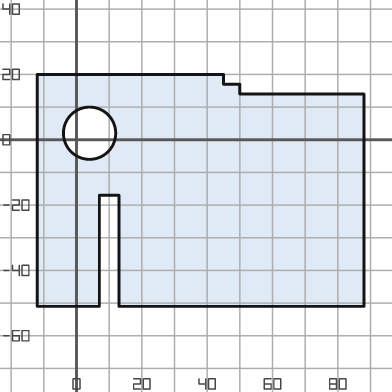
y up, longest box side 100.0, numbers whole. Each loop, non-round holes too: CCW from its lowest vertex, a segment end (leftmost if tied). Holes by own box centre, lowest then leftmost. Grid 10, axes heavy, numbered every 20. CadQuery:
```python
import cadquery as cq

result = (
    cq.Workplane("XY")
    .moveTo(-12.0, -51.0)
    .lineTo(7.0, -51.0)
    .lineTo(7.0, -17.0)
    .lineTo(13.0, -17.0)
    .lineTo(13.0, -51.0)
    .lineTo(88.0, -51.0)
    .lineTo(88.0, 14.0)
    .lineTo(50.0, 14.0)
    .lineTo(50.0, 17.0)
    .lineTo(45.0, 17.0)
    .lineTo(45.0, 20.0)
    .lineTo(-12.0, 20.0)
    .close()
    .moveTo(4.0, 2.0)
    .circle(8.0)
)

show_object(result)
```